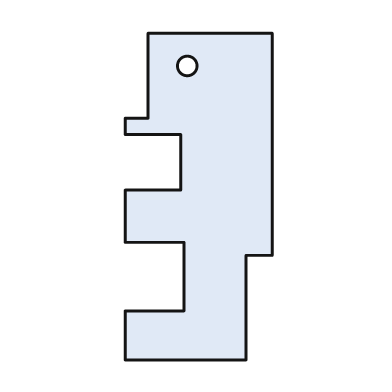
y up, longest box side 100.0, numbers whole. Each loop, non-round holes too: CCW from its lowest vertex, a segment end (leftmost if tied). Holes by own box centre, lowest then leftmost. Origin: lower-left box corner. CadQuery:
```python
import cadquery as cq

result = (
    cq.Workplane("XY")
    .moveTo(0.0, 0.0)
    .lineTo(37.0, 0.0)
    .lineTo(37.0, 32.0)
    .lineTo(45.0, 32.0)
    .lineTo(45.0, 100.0)
    .lineTo(7.0, 100.0)
    .lineTo(7.0, 74.0)
    .lineTo(0.0, 74.0)
    .lineTo(0.0, 69.0)
    .lineTo(17.0, 69.0)
    .lineTo(17.0, 52.0)
    .lineTo(0.0, 52.0)
    .lineTo(0.0, 36.0)
    .lineTo(18.0, 36.0)
    .lineTo(18.0, 15.0)
    .lineTo(0.0, 15.0)
    .close()
    .moveTo(19.0, 90.0)
    .circle(3.0)
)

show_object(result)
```